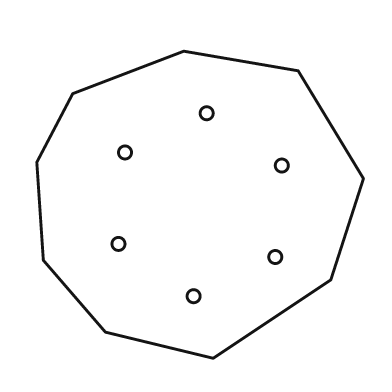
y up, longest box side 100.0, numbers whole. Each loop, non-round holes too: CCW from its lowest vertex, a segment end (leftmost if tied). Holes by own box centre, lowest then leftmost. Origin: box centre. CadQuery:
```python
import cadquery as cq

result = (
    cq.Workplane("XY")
    .moveTo(4.0, -47.0)
    .lineTo(40.0, -23.0)
    .lineTo(50.0, 8.0)
    .lineTo(30.0, 41.0)
    .lineTo(-5.0, 47.0)
    .lineTo(-39.0, 34.0)
    .lineTo(-50.0, 13.0)
    .lineTo(-48.0, -17.0)
    .lineTo(-29.0, -39.0)
    .close()
    .moveTo(-2.0, -28.0)
    .circle(2.0)
    .moveTo(23.0, -16.0)
    .circle(2.0)
    .moveTo(-25.0, -12.0)
    .circle(2.0)
    .moveTo(25.0, 12.0)
    .circle(2.0)
    .moveTo(-23.0, 16.0)
    .circle(2.0)
    .moveTo(2.0, 28.0)
    .circle(2.0)
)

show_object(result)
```